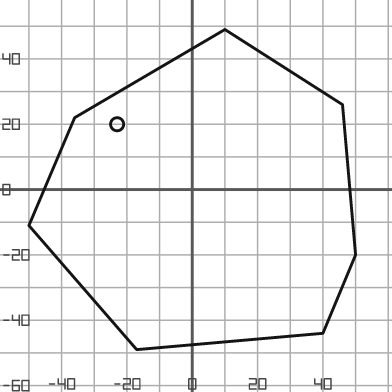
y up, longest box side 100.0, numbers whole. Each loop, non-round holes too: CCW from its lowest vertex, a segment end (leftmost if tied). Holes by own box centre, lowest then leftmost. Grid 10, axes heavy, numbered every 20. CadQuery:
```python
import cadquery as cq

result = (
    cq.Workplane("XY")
    .moveTo(-17.0, -49.0)
    .lineTo(40.0, -44.0)
    .lineTo(50.0, -20.0)
    .lineTo(46.0, 26.0)
    .lineTo(10.0, 49.0)
    .lineTo(-36.0, 22.0)
    .lineTo(-50.0, -11.0)
    .close()
    .moveTo(-23.0, 20.0)
    .circle(2.0)
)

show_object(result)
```